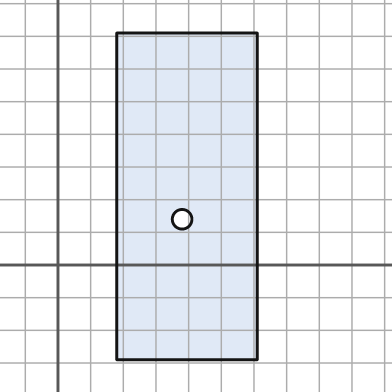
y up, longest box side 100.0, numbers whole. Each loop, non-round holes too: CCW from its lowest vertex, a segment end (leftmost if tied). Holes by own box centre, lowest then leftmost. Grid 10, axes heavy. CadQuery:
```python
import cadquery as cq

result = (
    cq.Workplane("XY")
    .moveTo(18.0, -29.0)
    .lineTo(61.0, -29.0)
    .lineTo(61.0, 71.0)
    .lineTo(18.0, 71.0)
    .close()
    .moveTo(38.0, 14.0)
    .circle(3.0)
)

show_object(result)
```